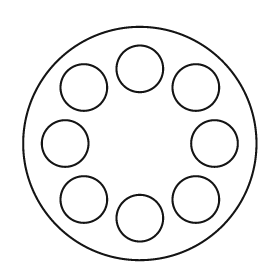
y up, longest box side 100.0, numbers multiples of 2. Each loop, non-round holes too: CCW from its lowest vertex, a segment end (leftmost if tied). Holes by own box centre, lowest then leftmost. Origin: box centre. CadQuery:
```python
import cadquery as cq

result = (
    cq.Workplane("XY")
    .moveTo(0.0, 0.0)
    .circle(50.0)
    .moveTo(0.0, -32.0)
    .circle(10.0)
    .moveTo(-24.0, -24.0)
    .circle(10.0)
    .moveTo(24.0, -24.0)
    .circle(10.0)
    .moveTo(-32.0, 0.0)
    .circle(10.0)
    .moveTo(32.0, 0.0)
    .circle(10.0)
    .moveTo(-24.0, 24.0)
    .circle(10.0)
    .moveTo(24.0, 24.0)
    .circle(10.0)
    .moveTo(0.0, 32.0)
    .circle(10.0)
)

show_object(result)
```